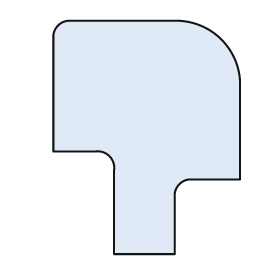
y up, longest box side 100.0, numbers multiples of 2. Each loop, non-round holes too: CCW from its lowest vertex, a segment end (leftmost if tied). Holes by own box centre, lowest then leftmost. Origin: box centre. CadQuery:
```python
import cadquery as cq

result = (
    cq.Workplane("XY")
    .moveTo(-14.0, -50.0)
    .lineTo(12.0, -50.0)
    .lineTo(12.0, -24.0)
    .threePointArc((14.0, -20.0), (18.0, -18.0))
    .lineTo(40.0, -18.0)
    .lineTo(40.0, 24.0)
    .threePointArc((32.0, 42.0), (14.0, 50.0))
    .lineTo(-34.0, 50.0)
    .threePointArc((-38.0, 48.0), (-40.0, 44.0))
    .lineTo(-40.0, -6.0)
    .lineTo(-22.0, -6.0)
    .threePointArc((-16.0, -8.0), (-14.0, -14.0))
    .close()
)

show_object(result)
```